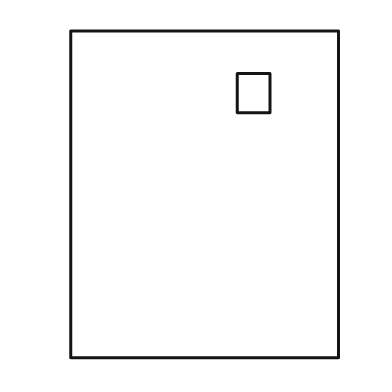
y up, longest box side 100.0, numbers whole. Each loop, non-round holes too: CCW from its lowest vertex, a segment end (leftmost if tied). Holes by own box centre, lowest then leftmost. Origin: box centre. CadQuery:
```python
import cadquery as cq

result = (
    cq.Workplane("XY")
    .moveTo(-41.0, -50.0)
    .lineTo(41.0, -50.0)
    .lineTo(41.0, 50.0)
    .lineTo(-41.0, 50.0)
    .close()
    .moveTo(10.0, 25.0)
    .lineTo(20.0, 25.0)
    .lineTo(20.0, 37.0)
    .lineTo(10.0, 37.0)
    .close()
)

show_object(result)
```